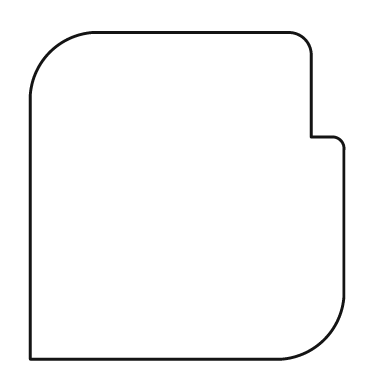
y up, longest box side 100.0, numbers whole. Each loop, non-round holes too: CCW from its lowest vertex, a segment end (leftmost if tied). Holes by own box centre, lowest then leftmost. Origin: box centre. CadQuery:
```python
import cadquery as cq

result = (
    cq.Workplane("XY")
    .moveTo(-48.0, -50.0)
    .lineTo(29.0, -50.0)
    .threePointArc((42.0, -44.0), (48.0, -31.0))
    .lineTo(48.0, 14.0)
    .threePointArc((47.0, 17.0), (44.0, 18.0))
    .lineTo(38.0, 18.0)
    .lineTo(38.0, 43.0)
    .threePointArc((36.0, 48.0), (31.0, 50.0))
    .lineTo(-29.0, 50.0)
    .threePointArc((-42.0, 44.0), (-48.0, 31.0))
    .close()
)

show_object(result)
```